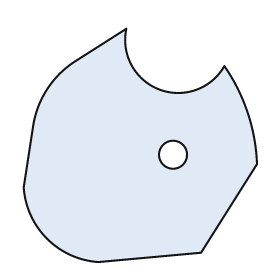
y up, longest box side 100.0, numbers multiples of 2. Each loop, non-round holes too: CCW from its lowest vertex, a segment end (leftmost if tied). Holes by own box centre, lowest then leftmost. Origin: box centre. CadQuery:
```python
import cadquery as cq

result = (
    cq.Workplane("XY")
    .moveTo(-18.0, -50.0)
    .lineTo(26.0, -46.0)
    .lineTo(50.0, -8.0)
    .threePointArc((46.0, 14.0), (36.0, 34.0))
    .threePointArc((8.0, 24.0), (-6.0, 50.0))
    .lineTo(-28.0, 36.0)
    .threePointArc((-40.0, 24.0), (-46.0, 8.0))
    .lineTo(-50.0, -18.0)
    .threePointArc((-40.0, -40.0), (-18.0, -50.0))
    .close()
    .moveTo(14.0, -4.0)
    .circle(6.0)
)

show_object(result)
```